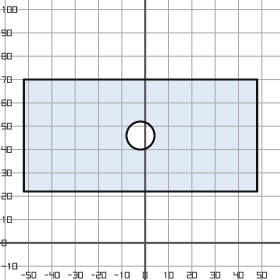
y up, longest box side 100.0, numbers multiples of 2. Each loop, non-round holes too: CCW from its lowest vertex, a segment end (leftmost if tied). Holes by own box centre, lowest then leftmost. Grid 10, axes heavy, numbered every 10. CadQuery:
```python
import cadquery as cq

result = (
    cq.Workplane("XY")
    .moveTo(-52.0, 22.0)
    .lineTo(48.0, 22.0)
    .lineTo(48.0, 70.0)
    .lineTo(-52.0, 70.0)
    .close()
    .moveTo(-2.0, 46.0)
    .circle(6.0)
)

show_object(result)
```